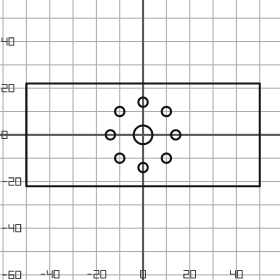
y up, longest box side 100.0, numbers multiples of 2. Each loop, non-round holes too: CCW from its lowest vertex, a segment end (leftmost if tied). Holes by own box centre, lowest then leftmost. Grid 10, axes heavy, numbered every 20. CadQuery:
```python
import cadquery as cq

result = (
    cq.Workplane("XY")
    .moveTo(-50.0, -22.0)
    .lineTo(50.0, -22.0)
    .lineTo(50.0, 22.0)
    .lineTo(-50.0, 22.0)
    .close()
    .moveTo(0.0, -14.0)
    .circle(2.0)
    .moveTo(-10.0, -10.0)
    .circle(2.0)
    .moveTo(10.0, -10.0)
    .circle(2.0)
    .moveTo(-14.0, 0.0)
    .circle(2.0)
    .moveTo(0.0, 0.0)
    .circle(4.0)
    .moveTo(14.0, 0.0)
    .circle(2.0)
    .moveTo(-10.0, 10.0)
    .circle(2.0)
    .moveTo(10.0, 10.0)
    .circle(2.0)
    .moveTo(0.0, 14.0)
    .circle(2.0)
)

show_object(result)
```